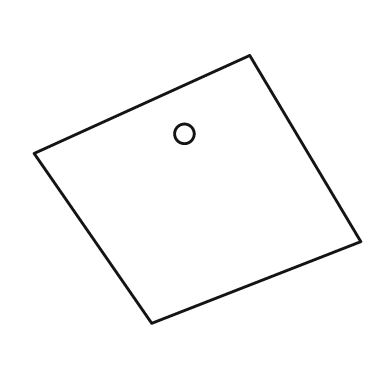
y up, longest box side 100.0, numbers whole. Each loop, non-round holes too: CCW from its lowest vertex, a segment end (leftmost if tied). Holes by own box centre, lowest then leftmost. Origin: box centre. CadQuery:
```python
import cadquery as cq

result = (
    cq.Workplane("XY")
    .moveTo(-14.0, -41.0)
    .lineTo(50.0, -16.0)
    .lineTo(16.0, 41.0)
    .lineTo(-50.0, 11.0)
    .close()
    .moveTo(-4.0, 17.0)
    .circle(3.0)
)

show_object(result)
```